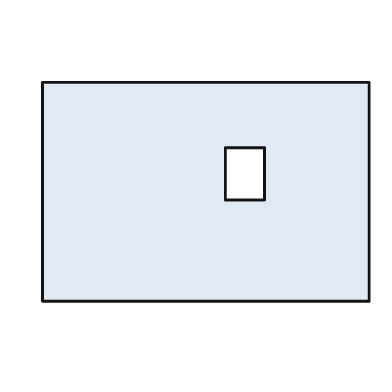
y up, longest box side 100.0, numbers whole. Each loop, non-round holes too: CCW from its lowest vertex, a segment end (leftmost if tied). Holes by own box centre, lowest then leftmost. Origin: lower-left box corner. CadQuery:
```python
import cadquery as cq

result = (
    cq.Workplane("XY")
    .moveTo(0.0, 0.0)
    .lineTo(100.0, 0.0)
    .lineTo(100.0, 67.0)
    .lineTo(0.0, 67.0)
    .close()
    .moveTo(56.0, 31.0)
    .lineTo(68.0, 31.0)
    .lineTo(68.0, 47.0)
    .lineTo(56.0, 47.0)
    .close()
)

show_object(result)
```